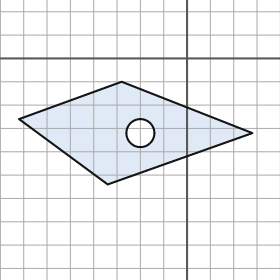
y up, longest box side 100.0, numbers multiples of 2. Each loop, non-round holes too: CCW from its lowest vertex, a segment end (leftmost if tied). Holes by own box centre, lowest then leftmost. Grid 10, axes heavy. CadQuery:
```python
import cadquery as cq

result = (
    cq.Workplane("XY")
    .moveTo(-34.0, -54.0)
    .lineTo(28.0, -32.0)
    .lineTo(-28.0, -10.0)
    .lineTo(-72.0, -26.0)
    .close()
    .moveTo(-20.0, -32.0)
    .circle(6.0)
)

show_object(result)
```